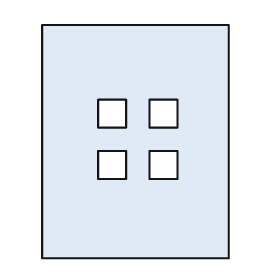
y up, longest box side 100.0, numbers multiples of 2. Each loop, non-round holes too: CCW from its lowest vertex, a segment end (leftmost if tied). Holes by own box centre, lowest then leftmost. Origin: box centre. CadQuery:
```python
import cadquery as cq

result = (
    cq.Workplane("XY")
    .moveTo(-40.0, -50.0)
    .lineTo(40.0, -50.0)
    .lineTo(40.0, 50.0)
    .lineTo(-40.0, 50.0)
    .close()
    .moveTo(-16.0, -16.0)
    .lineTo(-4.0, -16.0)
    .lineTo(-4.0, -4.0)
    .lineTo(-16.0, -4.0)
    .close()
    .moveTo(6.0, -16.0)
    .lineTo(18.0, -16.0)
    .lineTo(18.0, -4.0)
    .lineTo(6.0, -4.0)
    .close()
    .moveTo(-16.0, 6.0)
    .lineTo(-4.0, 6.0)
    .lineTo(-4.0, 18.0)
    .lineTo(-16.0, 18.0)
    .close()
    .moveTo(6.0, 6.0)
    .lineTo(18.0, 6.0)
    .lineTo(18.0, 18.0)
    .lineTo(6.0, 18.0)
    .close()
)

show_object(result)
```